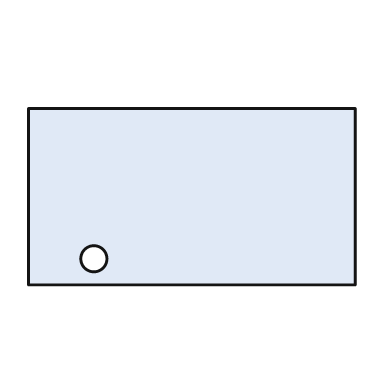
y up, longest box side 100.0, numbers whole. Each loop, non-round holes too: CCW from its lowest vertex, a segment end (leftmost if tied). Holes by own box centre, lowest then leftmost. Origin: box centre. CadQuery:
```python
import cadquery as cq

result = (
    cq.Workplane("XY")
    .moveTo(-50.0, -27.0)
    .lineTo(50.0, -27.0)
    .lineTo(50.0, 27.0)
    .lineTo(-50.0, 27.0)
    .close()
    .moveTo(-30.0, -19.0)
    .circle(4.0)
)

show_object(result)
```